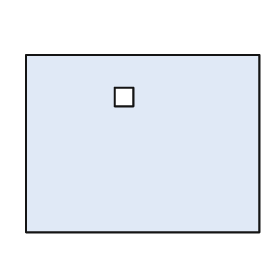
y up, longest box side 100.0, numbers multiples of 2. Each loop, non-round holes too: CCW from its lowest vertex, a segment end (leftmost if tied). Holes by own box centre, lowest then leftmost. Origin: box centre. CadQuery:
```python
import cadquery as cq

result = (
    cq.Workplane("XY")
    .moveTo(-50.0, -38.0)
    .lineTo(50.0, -38.0)
    .lineTo(50.0, 38.0)
    .lineTo(-50.0, 38.0)
    .close()
    .moveTo(-12.0, 16.0)
    .lineTo(-4.0, 16.0)
    .lineTo(-4.0, 24.0)
    .lineTo(-12.0, 24.0)
    .close()
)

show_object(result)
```